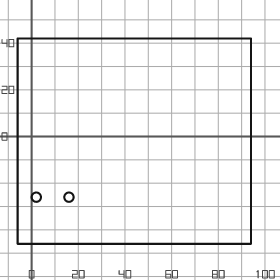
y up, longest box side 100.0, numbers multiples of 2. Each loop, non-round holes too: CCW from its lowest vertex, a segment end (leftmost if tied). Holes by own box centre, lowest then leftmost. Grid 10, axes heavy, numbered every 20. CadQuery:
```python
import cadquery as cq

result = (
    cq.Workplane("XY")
    .moveTo(-6.0, -46.0)
    .lineTo(94.0, -46.0)
    .lineTo(94.0, 42.0)
    .lineTo(-6.0, 42.0)
    .close()
    .moveTo(2.0, -26.0)
    .circle(2.0)
    .moveTo(16.0, -26.0)
    .circle(2.0)
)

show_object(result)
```